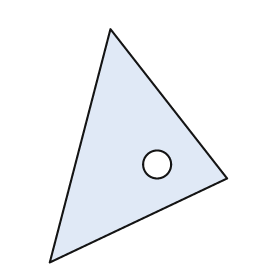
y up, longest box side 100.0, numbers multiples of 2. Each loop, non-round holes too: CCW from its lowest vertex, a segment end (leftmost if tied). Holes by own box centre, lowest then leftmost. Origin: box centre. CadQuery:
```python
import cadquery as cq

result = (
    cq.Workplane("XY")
    .moveTo(-38.0, -50.0)
    .lineTo(38.0, -14.0)
    .lineTo(-12.0, 50.0)
    .close()
    .moveTo(8.0, -8.0)
    .circle(6.0)
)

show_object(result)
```